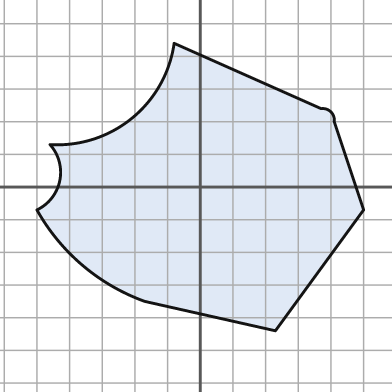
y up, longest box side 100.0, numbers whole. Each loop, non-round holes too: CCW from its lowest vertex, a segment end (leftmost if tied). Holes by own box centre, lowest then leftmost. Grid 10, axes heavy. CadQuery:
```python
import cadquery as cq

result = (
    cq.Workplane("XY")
    .moveTo(23.0, -44.0)
    .lineTo(50.0, -7.0)
    .lineTo(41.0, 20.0)
    .threePointArc((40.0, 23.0), (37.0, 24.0))
    .lineTo(-8.0, 44.0)
    .threePointArc((-21.0, 21.0), (-46.0, 13.0))
    .threePointArc((-43.0, 2.0), (-50.0, -7.0))
    .threePointArc((-36.0, -24.0), (-17.0, -35.0))
    .close()
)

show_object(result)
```